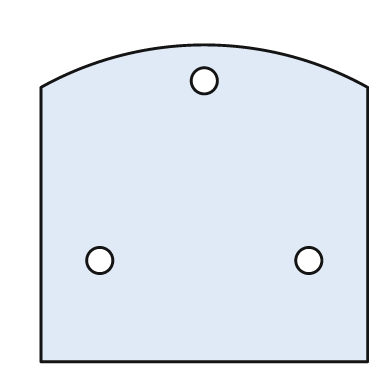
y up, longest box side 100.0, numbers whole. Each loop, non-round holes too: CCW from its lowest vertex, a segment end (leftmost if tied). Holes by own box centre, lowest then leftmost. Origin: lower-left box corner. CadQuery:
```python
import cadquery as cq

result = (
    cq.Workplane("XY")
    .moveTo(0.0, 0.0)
    .lineTo(100.0, 0.0)
    .lineTo(100.0, 84.0)
    .threePointArc((50.0, 97.0), (0.0, 84.0))
    .close()
    .moveTo(18.0, 31.0)
    .circle(4.0)
    .moveTo(82.0, 31.0)
    .circle(4.0)
    .moveTo(50.0, 86.0)
    .circle(4.0)
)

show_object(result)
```